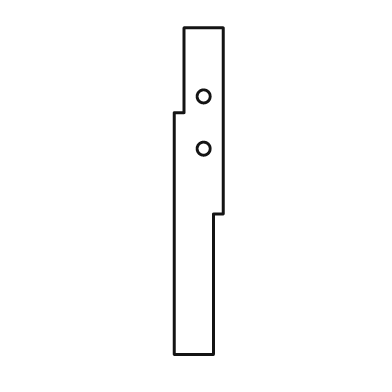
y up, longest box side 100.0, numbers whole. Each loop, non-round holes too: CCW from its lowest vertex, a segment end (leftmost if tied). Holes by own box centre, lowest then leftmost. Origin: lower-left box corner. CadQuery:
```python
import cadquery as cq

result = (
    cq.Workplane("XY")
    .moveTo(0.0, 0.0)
    .lineTo(12.0, 0.0)
    .lineTo(12.0, 43.0)
    .lineTo(15.0, 43.0)
    .lineTo(15.0, 100.0)
    .lineTo(3.0, 100.0)
    .lineTo(3.0, 74.0)
    .lineTo(0.0, 74.0)
    .close()
    .moveTo(9.0, 63.0)
    .circle(2.0)
    .moveTo(9.0, 79.0)
    .circle(2.0)
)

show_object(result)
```